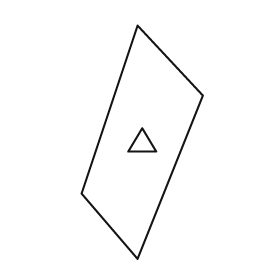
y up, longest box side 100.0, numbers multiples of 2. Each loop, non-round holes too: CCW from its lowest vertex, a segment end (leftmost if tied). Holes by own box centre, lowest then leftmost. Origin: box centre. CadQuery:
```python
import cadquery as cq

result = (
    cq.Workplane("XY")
    .moveTo(-2.0, -50.0)
    .lineTo(26.0, 20.0)
    .lineTo(-2.0, 50.0)
    .lineTo(-26.0, -22.0)
    .close()
    .moveTo(-6.0, -4.0)
    .lineTo(6.0, -4.0)
    .lineTo(0.0, 6.0)
    .close()
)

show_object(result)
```